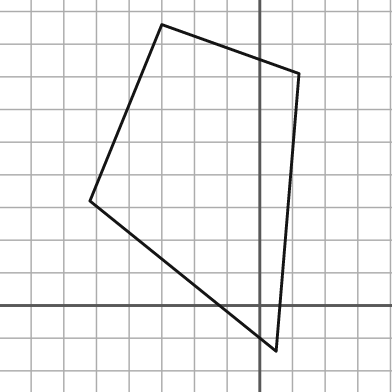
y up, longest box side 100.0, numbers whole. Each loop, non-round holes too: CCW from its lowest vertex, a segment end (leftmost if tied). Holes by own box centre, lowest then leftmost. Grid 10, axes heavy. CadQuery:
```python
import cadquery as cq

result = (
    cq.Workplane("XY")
    .moveTo(5.0, -14.0)
    .lineTo(12.0, 71.0)
    .lineTo(-30.0, 86.0)
    .lineTo(-52.0, 32.0)
    .close()
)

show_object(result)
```